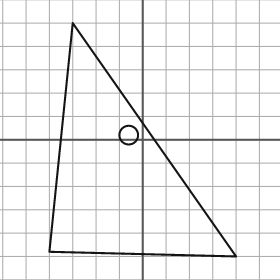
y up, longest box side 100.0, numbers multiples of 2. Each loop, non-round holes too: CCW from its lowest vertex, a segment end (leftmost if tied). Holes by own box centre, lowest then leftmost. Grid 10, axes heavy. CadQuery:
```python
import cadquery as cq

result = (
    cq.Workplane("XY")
    .moveTo(40.0, -50.0)
    .lineTo(-30.0, 50.0)
    .lineTo(-40.0, -48.0)
    .close()
    .moveTo(-6.0, 2.0)
    .circle(4.0)
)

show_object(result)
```